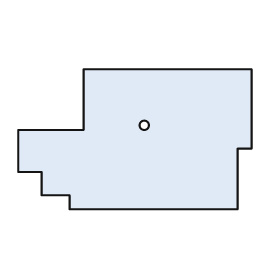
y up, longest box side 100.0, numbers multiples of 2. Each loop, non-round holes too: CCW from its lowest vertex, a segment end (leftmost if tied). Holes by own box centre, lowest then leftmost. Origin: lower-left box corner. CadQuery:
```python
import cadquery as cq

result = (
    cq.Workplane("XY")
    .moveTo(22.0, 0.0)
    .lineTo(94.0, 0.0)
    .lineTo(94.0, 26.0)
    .lineTo(100.0, 26.0)
    .lineTo(100.0, 60.0)
    .lineTo(28.0, 60.0)
    .lineTo(28.0, 34.0)
    .lineTo(0.0, 34.0)
    .lineTo(0.0, 16.0)
    .lineTo(10.0, 16.0)
    .lineTo(10.0, 6.0)
    .lineTo(22.0, 6.0)
    .close()
    .moveTo(54.0, 36.0)
    .circle(2.0)
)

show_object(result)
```